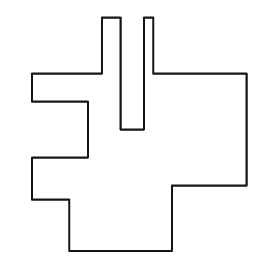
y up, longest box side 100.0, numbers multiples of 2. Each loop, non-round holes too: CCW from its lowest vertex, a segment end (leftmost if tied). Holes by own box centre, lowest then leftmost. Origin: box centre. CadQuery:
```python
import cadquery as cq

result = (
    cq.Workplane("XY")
    .moveTo(-30.0, -50.0)
    .lineTo(14.0, -50.0)
    .lineTo(14.0, -22.0)
    .lineTo(46.0, -22.0)
    .lineTo(46.0, 26.0)
    .lineTo(6.0, 26.0)
    .lineTo(6.0, 50.0)
    .lineTo(2.0, 50.0)
    .lineTo(2.0, 2.0)
    .lineTo(-8.0, 2.0)
    .lineTo(-8.0, 50.0)
    .lineTo(-16.0, 50.0)
    .lineTo(-16.0, 26.0)
    .lineTo(-46.0, 26.0)
    .lineTo(-46.0, 14.0)
    .lineTo(-22.0, 14.0)
    .lineTo(-22.0, -10.0)
    .lineTo(-46.0, -10.0)
    .lineTo(-46.0, -28.0)
    .lineTo(-30.0, -28.0)
    .close()
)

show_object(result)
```